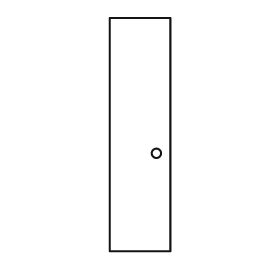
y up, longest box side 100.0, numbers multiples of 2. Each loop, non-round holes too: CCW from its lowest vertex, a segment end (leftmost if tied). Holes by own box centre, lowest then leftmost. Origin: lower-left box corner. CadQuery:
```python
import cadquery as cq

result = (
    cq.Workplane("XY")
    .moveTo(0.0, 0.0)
    .lineTo(26.0, 0.0)
    .lineTo(26.0, 100.0)
    .lineTo(0.0, 100.0)
    .close()
    .moveTo(20.0, 42.0)
    .circle(2.0)
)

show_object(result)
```